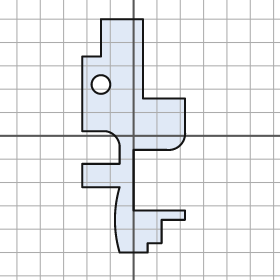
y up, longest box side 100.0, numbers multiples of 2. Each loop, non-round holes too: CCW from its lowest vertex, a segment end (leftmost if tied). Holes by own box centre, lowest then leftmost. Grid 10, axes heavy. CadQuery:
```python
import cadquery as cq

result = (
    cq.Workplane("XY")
    .moveTo(-6.0, -50.0)
    .lineTo(6.0, -50.0)
    .lineTo(6.0, -46.0)
    .lineTo(12.0, -46.0)
    .lineTo(12.0, -36.0)
    .lineTo(22.0, -36.0)
    .lineTo(22.0, -32.0)
    .lineTo(0.0, -32.0)
    .lineTo(0.0, -6.0)
    .lineTo(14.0, -6.0)
    .threePointArc((20.0, -4.0), (22.0, 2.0))
    .lineTo(22.0, 16.0)
    .lineTo(4.0, 16.0)
    .lineTo(4.0, 50.0)
    .lineTo(-14.0, 50.0)
    .lineTo(-14.0, 34.0)
    .lineTo(-22.0, 34.0)
    .lineTo(-22.0, 2.0)
    .lineTo(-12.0, 2.0)
    .threePointArc((-8.0, 0.0), (-6.0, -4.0))
    .lineTo(-6.0, -12.0)
    .lineTo(-22.0, -12.0)
    .lineTo(-22.0, -22.0)
    .lineTo(-6.0, -22.0)
    .threePointArc((-8.0, -36.0), (-6.0, -50.0))
    .close()
    .moveTo(-14.0, 22.0)
    .circle(4.0)
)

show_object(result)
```